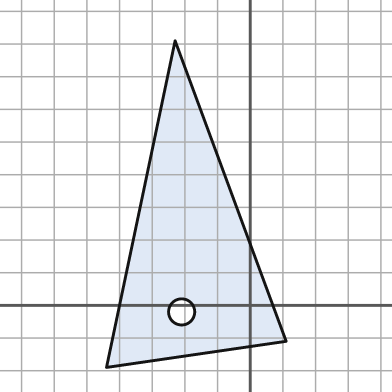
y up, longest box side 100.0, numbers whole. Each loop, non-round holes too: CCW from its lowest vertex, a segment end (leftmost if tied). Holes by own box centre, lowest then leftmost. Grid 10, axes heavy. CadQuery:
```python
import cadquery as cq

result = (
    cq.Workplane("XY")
    .moveTo(-44.0, -19.0)
    .lineTo(11.0, -11.0)
    .lineTo(-23.0, 81.0)
    .close()
    .moveTo(-21.0, -2.0)
    .circle(4.0)
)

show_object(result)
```